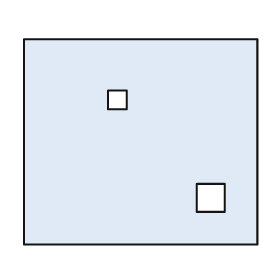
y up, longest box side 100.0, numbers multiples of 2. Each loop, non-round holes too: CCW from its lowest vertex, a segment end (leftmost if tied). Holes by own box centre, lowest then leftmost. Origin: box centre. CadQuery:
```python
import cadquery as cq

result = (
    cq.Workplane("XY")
    .moveTo(-50.0, -44.0)
    .lineTo(50.0, -44.0)
    .lineTo(50.0, 44.0)
    .lineTo(-50.0, 44.0)
    .close()
    .moveTo(24.0, -30.0)
    .lineTo(36.0, -30.0)
    .lineTo(36.0, -18.0)
    .lineTo(24.0, -18.0)
    .close()
    .moveTo(-14.0, 14.0)
    .lineTo(-6.0, 14.0)
    .lineTo(-6.0, 22.0)
    .lineTo(-14.0, 22.0)
    .close()
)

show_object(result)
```